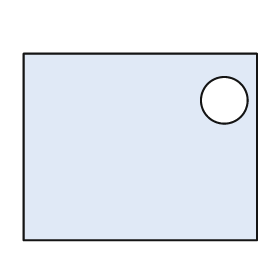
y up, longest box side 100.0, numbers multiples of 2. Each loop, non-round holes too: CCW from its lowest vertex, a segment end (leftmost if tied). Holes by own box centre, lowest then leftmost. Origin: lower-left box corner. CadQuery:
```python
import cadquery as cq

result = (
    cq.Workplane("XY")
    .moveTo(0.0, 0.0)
    .lineTo(100.0, 0.0)
    .lineTo(100.0, 80.0)
    .lineTo(0.0, 80.0)
    .close()
    .moveTo(86.0, 60.0)
    .circle(10.0)
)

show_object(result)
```